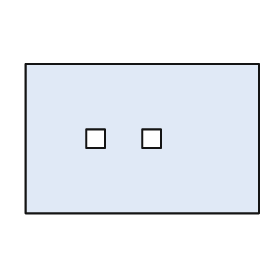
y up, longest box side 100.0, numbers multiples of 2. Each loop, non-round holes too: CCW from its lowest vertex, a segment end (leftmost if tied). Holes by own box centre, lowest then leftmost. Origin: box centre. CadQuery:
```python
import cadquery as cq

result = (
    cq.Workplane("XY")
    .moveTo(-50.0, -32.0)
    .lineTo(50.0, -32.0)
    .lineTo(50.0, 32.0)
    .lineTo(-50.0, 32.0)
    .close()
    .moveTo(-24.0, -4.0)
    .lineTo(-16.0, -4.0)
    .lineTo(-16.0, 4.0)
    .lineTo(-24.0, 4.0)
    .close()
    .moveTo(0.0, -4.0)
    .lineTo(8.0, -4.0)
    .lineTo(8.0, 4.0)
    .lineTo(0.0, 4.0)
    .close()
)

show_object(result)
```